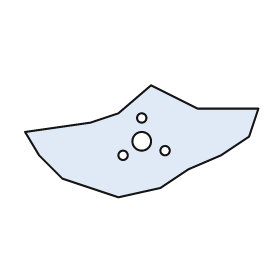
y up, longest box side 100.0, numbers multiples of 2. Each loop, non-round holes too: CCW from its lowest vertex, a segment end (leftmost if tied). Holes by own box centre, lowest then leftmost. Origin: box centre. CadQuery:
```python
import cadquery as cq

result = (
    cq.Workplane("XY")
    .moveTo(-10.0, -24.0)
    .lineTo(8.0, -20.0)
    .lineTo(20.0, -12.0)
    .lineTo(34.0, -6.0)
    .lineTo(46.0, 2.0)
    .lineTo(50.0, 14.0)
    .lineTo(24.0, 14.0)
    .lineTo(4.0, 24.0)
    .lineTo(-10.0, 12.0)
    .lineTo(-22.0, 8.0)
    .lineTo(-50.0, 4.0)
    .lineTo(-44.0, -6.0)
    .lineTo(-34.0, -16.0)
    .close()
    .moveTo(-8.0, -6.0)
    .circle(2.0)
    .moveTo(10.0, -4.0)
    .circle(2.0)
    .moveTo(0.0, 0.0)
    .circle(4.0)
    .moveTo(0.0, 10.0)
    .circle(2.0)
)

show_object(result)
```